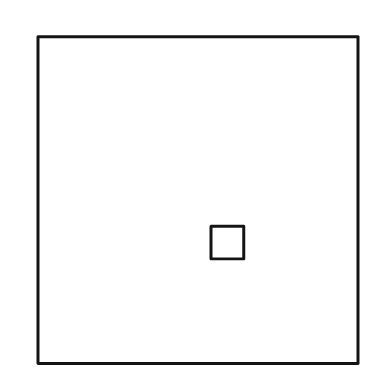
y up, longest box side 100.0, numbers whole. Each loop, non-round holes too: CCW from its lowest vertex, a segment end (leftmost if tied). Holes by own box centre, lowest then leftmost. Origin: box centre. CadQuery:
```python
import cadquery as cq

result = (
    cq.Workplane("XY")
    .moveTo(-49.0, -50.0)
    .lineTo(49.0, -50.0)
    .lineTo(49.0, 50.0)
    .lineTo(-49.0, 50.0)
    .close()
    .moveTo(4.0, -18.0)
    .lineTo(14.0, -18.0)
    .lineTo(14.0, -8.0)
    .lineTo(4.0, -8.0)
    .close()
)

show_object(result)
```